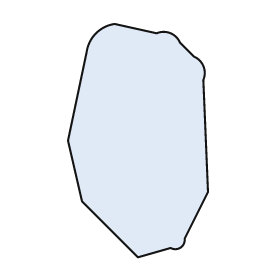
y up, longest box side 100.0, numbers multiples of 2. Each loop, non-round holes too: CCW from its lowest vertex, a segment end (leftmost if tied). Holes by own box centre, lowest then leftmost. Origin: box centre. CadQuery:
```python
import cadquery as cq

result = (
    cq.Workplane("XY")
    .moveTo(0.0, -50.0)
    .lineTo(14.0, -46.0)
    .threePointArc((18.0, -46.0), (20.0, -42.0))
    .lineTo(30.0, -22.0)
    .lineTo(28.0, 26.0)
    .threePointArc((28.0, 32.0), (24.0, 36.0))
    .lineTo(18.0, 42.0)
    .threePointArc((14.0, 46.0), (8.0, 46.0))
    .lineTo(-10.0, 50.0)
    .threePointArc((-18.0, 46.0), (-22.0, 38.0))
    .lineTo(-30.0, 0.0)
    .lineTo(-24.0, -26.0)
    .close()
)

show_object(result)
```